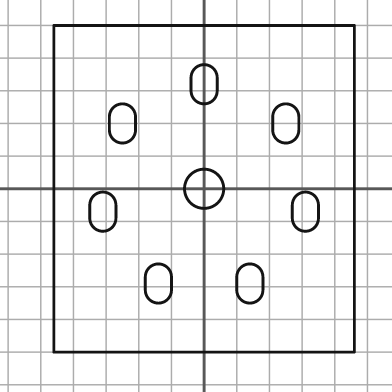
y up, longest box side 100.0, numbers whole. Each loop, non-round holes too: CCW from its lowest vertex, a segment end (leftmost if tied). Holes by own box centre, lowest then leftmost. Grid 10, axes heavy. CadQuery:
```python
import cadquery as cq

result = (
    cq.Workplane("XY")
    .moveTo(-46.0, -50.0)
    .lineTo(46.0, -50.0)
    .lineTo(46.0, 50.0)
    .lineTo(-46.0, 50.0)
    .close()
    .moveTo(-18.0, -31.0)
    .threePointArc((-14.0, -35.0), (-10.0, -31.0))
    .lineTo(-10.0, -27.0)
    .threePointArc((-14.0, -23.0), (-18.0, -27.0))
    .close()
    .moveTo(10.0, -31.0)
    .threePointArc((14.0, -35.0), (18.0, -31.0))
    .lineTo(18.0, -27.0)
    .threePointArc((14.0, -23.0), (10.0, -27.0))
    .close()
    .moveTo(-35.0, -9.0)
    .threePointArc((-31.0, -13.0), (-27.0, -9.0))
    .lineTo(-27.0, -5.0)
    .threePointArc((-31.0, -1.0), (-35.0, -5.0))
    .close()
    .moveTo(27.0, -9.0)
    .threePointArc((31.0, -13.0), (35.0, -9.0))
    .lineTo(35.0, -5.0)
    .threePointArc((31.0, -1.0), (27.0, -5.0))
    .close()
    .moveTo(0.0, 0.0)
    .circle(6.0)
    .moveTo(-29.0, 18.0)
    .threePointArc((-25.0, 14.0), (-21.0, 18.0))
    .lineTo(-21.0, 22.0)
    .threePointArc((-25.0, 26.0), (-29.0, 22.0))
    .close()
    .moveTo(21.0, 18.0)
    .threePointArc((25.0, 14.0), (29.0, 18.0))
    .lineTo(29.0, 22.0)
    .threePointArc((25.0, 26.0), (21.0, 22.0))
    .close()
    .moveTo(-4.0, 30.0)
    .threePointArc((0.0, 26.0), (4.0, 30.0))
    .lineTo(4.0, 34.0)
    .threePointArc((0.0, 38.0), (-4.0, 34.0))
    .close()
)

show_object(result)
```